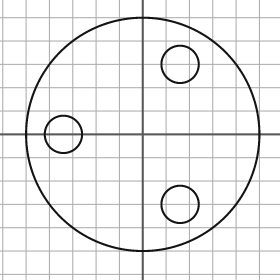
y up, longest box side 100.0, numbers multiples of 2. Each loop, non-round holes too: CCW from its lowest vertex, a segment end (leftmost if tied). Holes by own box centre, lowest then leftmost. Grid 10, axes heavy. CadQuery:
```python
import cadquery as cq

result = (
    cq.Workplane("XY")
    .moveTo(0.0, 0.0)
    .circle(50.0)
    .moveTo(16.0, -30.0)
    .circle(8.0)
    .moveTo(-34.0, 0.0)
    .circle(8.0)
    .moveTo(16.0, 30.0)
    .circle(8.0)
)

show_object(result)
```